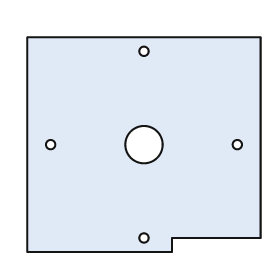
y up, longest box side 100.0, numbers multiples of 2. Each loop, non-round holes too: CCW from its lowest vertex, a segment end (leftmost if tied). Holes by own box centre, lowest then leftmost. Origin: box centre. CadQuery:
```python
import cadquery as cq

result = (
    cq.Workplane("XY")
    .moveTo(-50.0, -46.0)
    .lineTo(12.0, -46.0)
    .lineTo(12.0, -40.0)
    .lineTo(50.0, -40.0)
    .lineTo(50.0, 46.0)
    .lineTo(-50.0, 46.0)
    .close()
    .moveTo(0.0, -40.0)
    .circle(2.0)
    .moveTo(-40.0, 0.0)
    .circle(2.0)
    .moveTo(0.0, 0.0)
    .circle(8.0)
    .moveTo(40.0, 0.0)
    .circle(2.0)
    .moveTo(0.0, 40.0)
    .circle(2.0)
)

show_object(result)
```